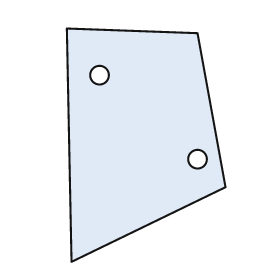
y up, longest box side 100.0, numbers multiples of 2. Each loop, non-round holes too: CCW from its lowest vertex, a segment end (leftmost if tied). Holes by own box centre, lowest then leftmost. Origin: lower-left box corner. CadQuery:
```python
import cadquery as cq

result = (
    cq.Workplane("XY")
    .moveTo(2.0, 0.0)
    .lineTo(68.0, 32.0)
    .lineTo(56.0, 98.0)
    .lineTo(0.0, 100.0)
    .close()
    .moveTo(56.0, 44.0)
    .circle(4.0)
    .moveTo(14.0, 80.0)
    .circle(4.0)
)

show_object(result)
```